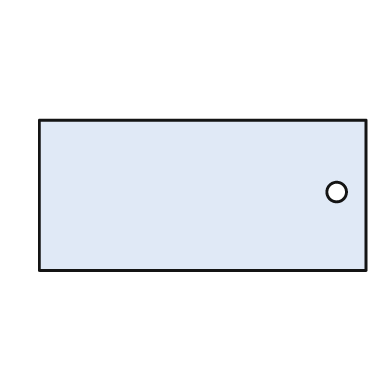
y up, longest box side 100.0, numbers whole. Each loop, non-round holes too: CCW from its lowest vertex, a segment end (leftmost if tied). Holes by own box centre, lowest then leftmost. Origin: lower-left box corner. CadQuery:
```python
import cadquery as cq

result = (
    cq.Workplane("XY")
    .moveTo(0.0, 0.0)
    .lineTo(100.0, 0.0)
    .lineTo(100.0, 46.0)
    .lineTo(0.0, 46.0)
    .close()
    .moveTo(91.0, 24.0)
    .circle(3.0)
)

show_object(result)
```